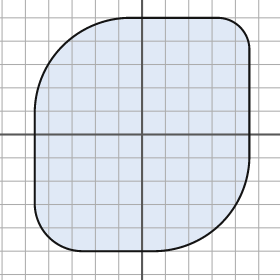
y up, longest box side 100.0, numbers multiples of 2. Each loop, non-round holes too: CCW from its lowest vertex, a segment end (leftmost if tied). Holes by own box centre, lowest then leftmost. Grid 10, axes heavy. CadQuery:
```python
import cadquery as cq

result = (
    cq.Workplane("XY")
    .moveTo(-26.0, -50.0)
    .lineTo(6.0, -50.0)
    .threePointArc((34.0, -38.0), (46.0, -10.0))
    .lineTo(46.0, 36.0)
    .threePointArc((42.0, 46.0), (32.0, 50.0))
    .lineTo(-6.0, 50.0)
    .threePointArc((-34.0, 38.0), (-46.0, 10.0))
    .lineTo(-46.0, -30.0)
    .threePointArc((-40.0, -44.0), (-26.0, -50.0))
    .close()
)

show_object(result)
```